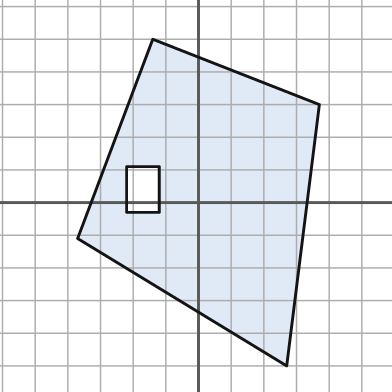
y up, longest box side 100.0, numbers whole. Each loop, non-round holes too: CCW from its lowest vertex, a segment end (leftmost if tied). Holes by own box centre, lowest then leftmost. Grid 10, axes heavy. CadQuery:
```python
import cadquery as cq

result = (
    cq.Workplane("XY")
    .moveTo(27.0, -50.0)
    .lineTo(37.0, 30.0)
    .lineTo(-14.0, 50.0)
    .lineTo(-37.0, -11.0)
    .close()
    .moveTo(-22.0, -3.0)
    .lineTo(-12.0, -3.0)
    .lineTo(-12.0, 11.0)
    .lineTo(-22.0, 11.0)
    .close()
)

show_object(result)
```